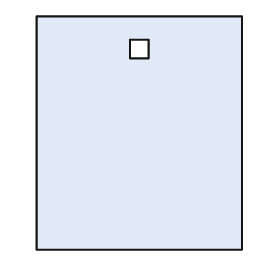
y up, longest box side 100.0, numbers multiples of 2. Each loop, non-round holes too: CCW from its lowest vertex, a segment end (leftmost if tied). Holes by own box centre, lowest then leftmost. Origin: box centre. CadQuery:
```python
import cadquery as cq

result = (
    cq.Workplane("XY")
    .moveTo(-44.0, -50.0)
    .lineTo(44.0, -50.0)
    .lineTo(44.0, 50.0)
    .lineTo(-44.0, 50.0)
    .close()
    .moveTo(-4.0, 32.0)
    .lineTo(4.0, 32.0)
    .lineTo(4.0, 40.0)
    .lineTo(-4.0, 40.0)
    .close()
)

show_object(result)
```